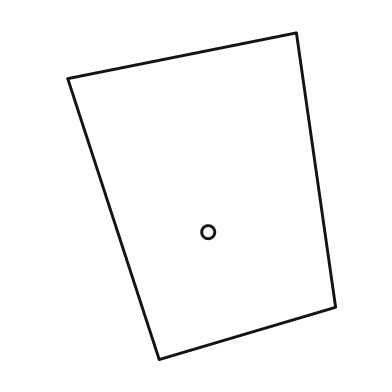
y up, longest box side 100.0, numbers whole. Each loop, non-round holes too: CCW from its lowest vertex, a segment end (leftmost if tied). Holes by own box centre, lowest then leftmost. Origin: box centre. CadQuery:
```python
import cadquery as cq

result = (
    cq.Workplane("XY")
    .moveTo(-13.0, -50.0)
    .lineTo(41.0, -34.0)
    .lineTo(29.0, 50.0)
    .lineTo(-41.0, 36.0)
    .close()
    .moveTo(2.0, -11.0)
    .circle(2.0)
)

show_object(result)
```